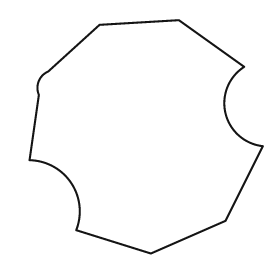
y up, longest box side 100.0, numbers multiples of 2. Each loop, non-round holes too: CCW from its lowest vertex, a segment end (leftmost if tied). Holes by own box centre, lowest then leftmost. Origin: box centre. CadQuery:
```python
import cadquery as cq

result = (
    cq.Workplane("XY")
    .moveTo(2.0, -50.0)
    .lineTo(34.0, -36.0)
    .lineTo(50.0, -4.0)
    .threePointArc((34.0, 10.0), (42.0, 30.0))
    .lineTo(14.0, 50.0)
    .lineTo(-20.0, 48.0)
    .lineTo(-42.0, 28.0)
    .threePointArc((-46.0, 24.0), (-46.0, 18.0))
    .lineTo(-50.0, -10.0)
    .threePointArc((-32.0, -20.0), (-30.0, -40.0))
    .close()
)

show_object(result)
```